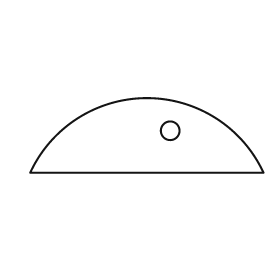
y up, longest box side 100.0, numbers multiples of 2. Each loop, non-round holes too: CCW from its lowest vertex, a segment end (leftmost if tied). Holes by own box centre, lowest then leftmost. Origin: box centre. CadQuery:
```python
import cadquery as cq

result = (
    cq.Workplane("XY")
    .moveTo(-50.0, -16.0)
    .lineTo(50.0, -16.0)
    .threePointArc((0.0, 16.0), (-50.0, -16.0))
    .close()
    .moveTo(10.0, 2.0)
    .circle(4.0)
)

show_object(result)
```